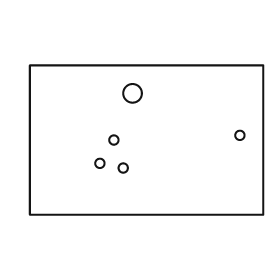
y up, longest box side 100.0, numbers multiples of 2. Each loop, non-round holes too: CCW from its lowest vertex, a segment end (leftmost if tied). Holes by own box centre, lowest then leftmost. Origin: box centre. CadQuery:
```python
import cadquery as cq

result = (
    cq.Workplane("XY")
    .moveTo(-50.0, -32.0)
    .lineTo(50.0, -32.0)
    .lineTo(50.0, 32.0)
    .lineTo(-50.0, 32.0)
    .close()
    .moveTo(-10.0, -12.0)
    .circle(2.0)
    .moveTo(-20.0, -10.0)
    .circle(2.0)
    .moveTo(-14.0, 0.0)
    .circle(2.0)
    .moveTo(40.0, 2.0)
    .circle(2.0)
    .moveTo(-6.0, 20.0)
    .circle(4.0)
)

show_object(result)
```